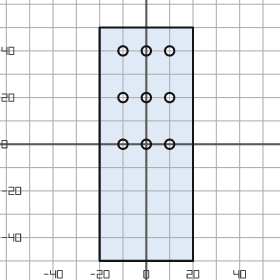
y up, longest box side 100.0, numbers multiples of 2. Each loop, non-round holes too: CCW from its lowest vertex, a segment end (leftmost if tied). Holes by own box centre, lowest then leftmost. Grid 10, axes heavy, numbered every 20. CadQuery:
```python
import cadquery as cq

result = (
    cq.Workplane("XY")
    .moveTo(-20.0, -50.0)
    .lineTo(20.0, -50.0)
    .lineTo(20.0, 50.0)
    .lineTo(-20.0, 50.0)
    .close()
    .moveTo(-10.0, 0.0)
    .circle(2.0)
    .moveTo(0.0, 0.0)
    .circle(2.0)
    .moveTo(10.0, 0.0)
    .circle(2.0)
    .moveTo(-10.0, 20.0)
    .circle(2.0)
    .moveTo(0.0, 20.0)
    .circle(2.0)
    .moveTo(10.0, 20.0)
    .circle(2.0)
    .moveTo(-10.0, 40.0)
    .circle(2.0)
    .moveTo(0.0, 40.0)
    .circle(2.0)
    .moveTo(10.0, 40.0)
    .circle(2.0)
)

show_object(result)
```